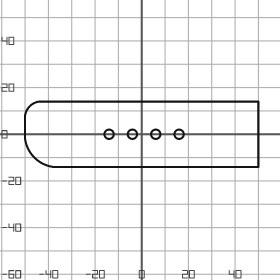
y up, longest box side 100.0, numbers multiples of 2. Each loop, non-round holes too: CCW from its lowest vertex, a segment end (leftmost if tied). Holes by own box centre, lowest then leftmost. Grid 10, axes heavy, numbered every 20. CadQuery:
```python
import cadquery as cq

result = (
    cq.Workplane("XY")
    .moveTo(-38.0, -14.0)
    .lineTo(50.0, -14.0)
    .lineTo(50.0, 14.0)
    .lineTo(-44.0, 14.0)
    .threePointArc((-48.0, 12.0), (-50.0, 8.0))
    .lineTo(-50.0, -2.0)
    .threePointArc((-46.0, -10.0), (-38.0, -14.0))
    .close()
    .moveTo(-14.0, 0.0)
    .circle(2.0)
    .moveTo(-4.0, 0.0)
    .circle(2.0)
    .moveTo(6.0, 0.0)
    .circle(2.0)
    .moveTo(16.0, 0.0)
    .circle(2.0)
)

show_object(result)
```